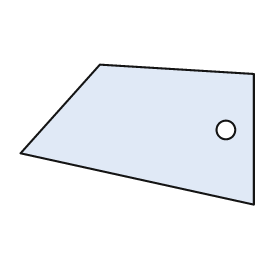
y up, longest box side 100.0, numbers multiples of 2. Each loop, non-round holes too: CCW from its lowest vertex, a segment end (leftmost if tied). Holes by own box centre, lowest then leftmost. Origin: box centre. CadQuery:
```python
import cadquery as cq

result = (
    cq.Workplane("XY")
    .moveTo(50.0, -30.0)
    .lineTo(50.0, 26.0)
    .lineTo(-16.0, 30.0)
    .lineTo(-50.0, -8.0)
    .close()
    .moveTo(38.0, 2.0)
    .circle(4.0)
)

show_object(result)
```